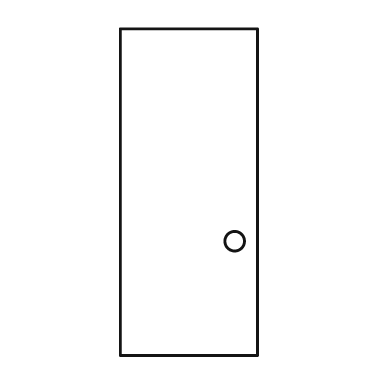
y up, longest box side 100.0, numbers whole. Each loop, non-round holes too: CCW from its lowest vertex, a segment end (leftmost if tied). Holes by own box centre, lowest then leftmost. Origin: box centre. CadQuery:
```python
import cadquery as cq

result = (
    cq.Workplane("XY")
    .moveTo(-21.0, -50.0)
    .lineTo(21.0, -50.0)
    .lineTo(21.0, 50.0)
    .lineTo(-21.0, 50.0)
    .close()
    .moveTo(14.0, -15.0)
    .circle(3.0)
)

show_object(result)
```